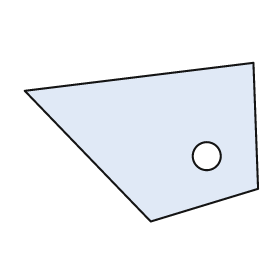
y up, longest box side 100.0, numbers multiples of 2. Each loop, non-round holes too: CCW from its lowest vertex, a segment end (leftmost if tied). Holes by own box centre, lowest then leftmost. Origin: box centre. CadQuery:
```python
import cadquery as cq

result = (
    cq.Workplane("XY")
    .moveTo(4.0, -34.0)
    .lineTo(50.0, -20.0)
    .lineTo(48.0, 34.0)
    .lineTo(-50.0, 22.0)
    .close()
    .moveTo(28.0, -6.0)
    .circle(6.0)
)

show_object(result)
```